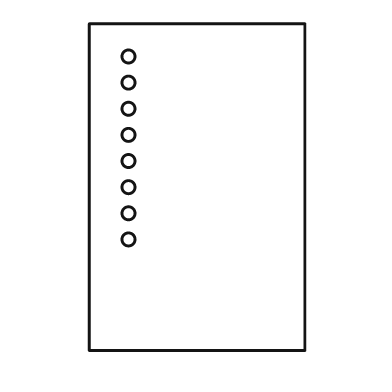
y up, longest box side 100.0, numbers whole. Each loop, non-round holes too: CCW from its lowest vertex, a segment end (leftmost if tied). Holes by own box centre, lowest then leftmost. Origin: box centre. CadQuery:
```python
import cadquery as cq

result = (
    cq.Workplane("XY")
    .moveTo(-33.0, -50.0)
    .lineTo(33.0, -50.0)
    .lineTo(33.0, 50.0)
    .lineTo(-33.0, 50.0)
    .close()
    .moveTo(-21.0, -16.0)
    .circle(2.0)
    .moveTo(-21.0, -8.0)
    .circle(2.0)
    .moveTo(-21.0, 0.0)
    .circle(2.0)
    .moveTo(-21.0, 8.0)
    .circle(2.0)
    .moveTo(-21.0, 16.0)
    .circle(2.0)
    .moveTo(-21.0, 24.0)
    .circle(2.0)
    .moveTo(-21.0, 32.0)
    .circle(2.0)
    .moveTo(-21.0, 40.0)
    .circle(2.0)
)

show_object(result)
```